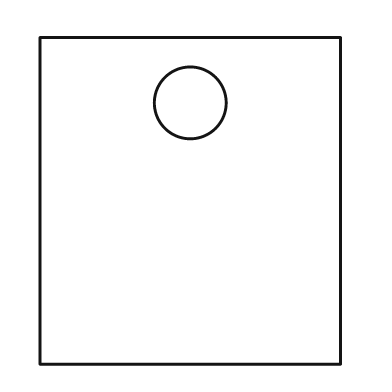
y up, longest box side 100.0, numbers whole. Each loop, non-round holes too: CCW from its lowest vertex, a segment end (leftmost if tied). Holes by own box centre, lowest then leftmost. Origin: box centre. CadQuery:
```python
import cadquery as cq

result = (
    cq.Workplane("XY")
    .moveTo(-46.0, -50.0)
    .lineTo(46.0, -50.0)
    .lineTo(46.0, 50.0)
    .lineTo(-46.0, 50.0)
    .close()
    .moveTo(0.0, 30.0)
    .circle(11.0)
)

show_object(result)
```